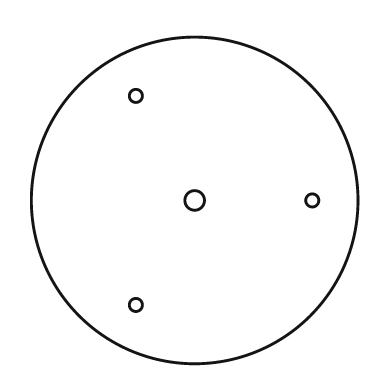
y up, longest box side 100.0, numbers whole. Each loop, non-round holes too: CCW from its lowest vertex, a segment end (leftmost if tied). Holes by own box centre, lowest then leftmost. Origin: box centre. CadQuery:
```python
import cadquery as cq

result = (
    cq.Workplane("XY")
    .moveTo(0.0, 0.0)
    .circle(50.0)
    .moveTo(-18.0, -32.0)
    .circle(2.0)
    .moveTo(0.0, 0.0)
    .circle(3.0)
    .moveTo(36.0, 0.0)
    .circle(2.0)
    .moveTo(-18.0, 32.0)
    .circle(2.0)
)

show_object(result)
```